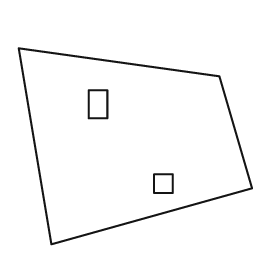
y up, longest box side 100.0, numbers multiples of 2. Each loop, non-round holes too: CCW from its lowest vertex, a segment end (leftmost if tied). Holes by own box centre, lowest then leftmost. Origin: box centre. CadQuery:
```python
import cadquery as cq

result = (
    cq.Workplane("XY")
    .moveTo(-36.0, -42.0)
    .lineTo(50.0, -18.0)
    .lineTo(36.0, 30.0)
    .lineTo(-50.0, 42.0)
    .close()
    .moveTo(8.0, -20.0)
    .lineTo(16.0, -20.0)
    .lineTo(16.0, -12.0)
    .lineTo(8.0, -12.0)
    .close()
    .moveTo(-20.0, 12.0)
    .lineTo(-12.0, 12.0)
    .lineTo(-12.0, 24.0)
    .lineTo(-20.0, 24.0)
    .close()
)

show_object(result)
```